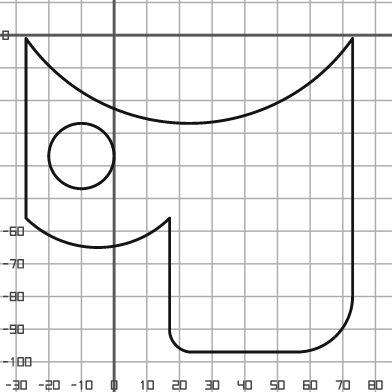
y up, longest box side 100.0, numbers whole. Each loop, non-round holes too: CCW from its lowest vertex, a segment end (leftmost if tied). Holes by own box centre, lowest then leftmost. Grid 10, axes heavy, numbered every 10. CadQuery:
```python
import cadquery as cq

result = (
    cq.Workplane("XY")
    .moveTo(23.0, -97.0)
    .lineTo(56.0, -97.0)
    .threePointArc((68.0, -92.0), (73.0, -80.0))
    .lineTo(73.0, -1.0)
    .threePointArc((23.0, -27.0), (-27.0, -1.0))
    .lineTo(-27.0, -56.0)
    .threePointArc((-5.0, -65.0), (17.0, -56.0))
    .lineTo(17.0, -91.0)
    .threePointArc((19.0, -95.0), (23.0, -97.0))
    .close()
    .moveTo(-10.0, -37.0)
    .circle(10.0)
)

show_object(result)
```